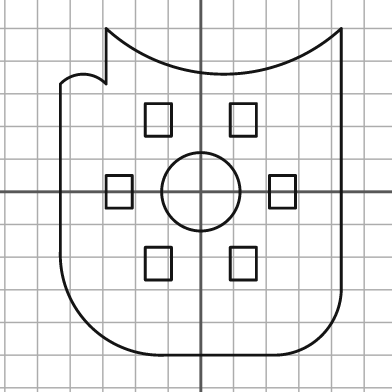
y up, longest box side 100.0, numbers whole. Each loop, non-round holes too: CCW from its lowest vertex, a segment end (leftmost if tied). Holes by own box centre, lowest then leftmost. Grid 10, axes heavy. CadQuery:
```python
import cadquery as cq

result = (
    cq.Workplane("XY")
    .moveTo(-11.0, -50.0)
    .lineTo(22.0, -50.0)
    .threePointArc((37.0, -44.0), (43.0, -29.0))
    .lineTo(43.0, 50.0)
    .threePointArc((7.0, 36.0), (-29.0, 50.0))
    .lineTo(-29.0, 33.0)
    .threePointArc((-36.0, 36.0), (-43.0, 33.0))
    .lineTo(-43.0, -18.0)
    .threePointArc((-34.0, -41.0), (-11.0, -50.0))
    .close()
    .moveTo(-17.0, -27.0)
    .lineTo(-9.0, -27.0)
    .lineTo(-9.0, -17.0)
    .lineTo(-17.0, -17.0)
    .close()
    .moveTo(9.0, -27.0)
    .lineTo(17.0, -27.0)
    .lineTo(17.0, -17.0)
    .lineTo(9.0, -17.0)
    .close()
    .moveTo(-29.0, -5.0)
    .lineTo(-21.0, -5.0)
    .lineTo(-21.0, 5.0)
    .lineTo(-29.0, 5.0)
    .close()
    .moveTo(0.0, 0.0)
    .circle(12.0)
    .moveTo(21.0, -5.0)
    .lineTo(29.0, -5.0)
    .lineTo(29.0, 5.0)
    .lineTo(21.0, 5.0)
    .close()
    .moveTo(-17.0, 17.0)
    .lineTo(-9.0, 17.0)
    .lineTo(-9.0, 27.0)
    .lineTo(-17.0, 27.0)
    .close()
    .moveTo(9.0, 17.0)
    .lineTo(17.0, 17.0)
    .lineTo(17.0, 27.0)
    .lineTo(9.0, 27.0)
    .close()
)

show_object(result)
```